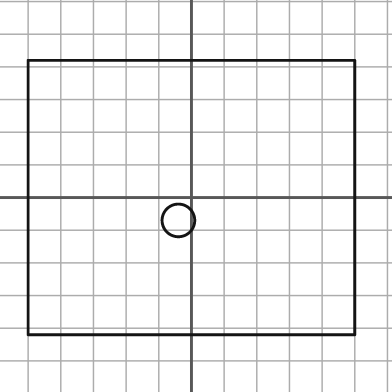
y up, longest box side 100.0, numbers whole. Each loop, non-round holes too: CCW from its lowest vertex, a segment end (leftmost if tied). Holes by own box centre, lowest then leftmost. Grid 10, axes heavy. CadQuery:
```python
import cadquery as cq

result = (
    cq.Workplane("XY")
    .moveTo(-50.0, -42.0)
    .lineTo(50.0, -42.0)
    .lineTo(50.0, 42.0)
    .lineTo(-50.0, 42.0)
    .close()
    .moveTo(-4.0, -7.0)
    .circle(5.0)
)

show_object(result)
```